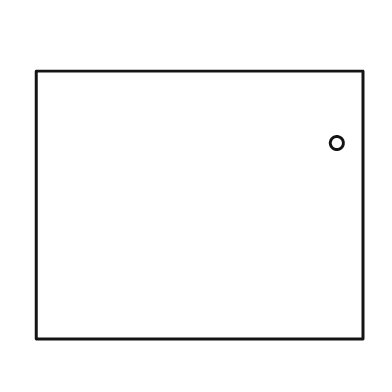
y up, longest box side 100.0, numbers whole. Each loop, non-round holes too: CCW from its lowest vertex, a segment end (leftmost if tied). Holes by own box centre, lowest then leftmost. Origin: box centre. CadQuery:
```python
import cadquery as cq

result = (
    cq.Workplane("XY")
    .moveTo(-50.0, -41.0)
    .lineTo(50.0, -41.0)
    .lineTo(50.0, 41.0)
    .lineTo(-50.0, 41.0)
    .close()
    .moveTo(42.0, 19.0)
    .circle(2.0)
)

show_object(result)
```